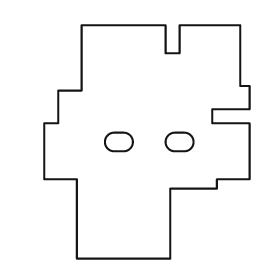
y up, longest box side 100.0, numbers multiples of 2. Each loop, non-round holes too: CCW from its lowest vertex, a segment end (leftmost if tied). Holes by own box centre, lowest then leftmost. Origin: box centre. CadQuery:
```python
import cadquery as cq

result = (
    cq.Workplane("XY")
    .moveTo(-30.0, -50.0)
    .lineTo(10.0, -50.0)
    .lineTo(10.0, -20.0)
    .lineTo(30.0, -20.0)
    .lineTo(30.0, -16.0)
    .lineTo(44.0, -16.0)
    .lineTo(44.0, 8.0)
    .lineTo(28.0, 8.0)
    .lineTo(28.0, 14.0)
    .lineTo(44.0, 14.0)
    .lineTo(44.0, 24.0)
    .lineTo(40.0, 24.0)
    .lineTo(40.0, 50.0)
    .lineTo(14.0, 50.0)
    .lineTo(14.0, 38.0)
    .lineTo(8.0, 38.0)
    .lineTo(8.0, 50.0)
    .lineTo(-28.0, 50.0)
    .lineTo(-28.0, 22.0)
    .lineTo(-38.0, 22.0)
    .lineTo(-38.0, 8.0)
    .lineTo(-44.0, 8.0)
    .lineTo(-44.0, -16.0)
    .lineTo(-30.0, -16.0)
    .close()
    .moveTo(-14.0, -4.0)
    .lineTo(-10.0, -4.0)
    .threePointArc((-6.0, 0.0), (-10.0, 4.0))
    .lineTo(-14.0, 4.0)
    .threePointArc((-18.0, 0.0), (-14.0, -4.0))
    .close()
    .moveTo(12.0, -4.0)
    .lineTo(16.0, -4.0)
    .threePointArc((20.0, 0.0), (16.0, 4.0))
    .lineTo(12.0, 4.0)
    .threePointArc((8.0, 0.0), (12.0, -4.0))
    .close()
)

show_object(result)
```